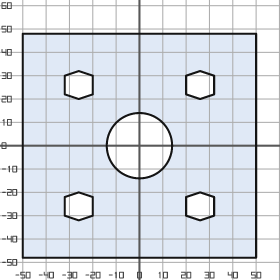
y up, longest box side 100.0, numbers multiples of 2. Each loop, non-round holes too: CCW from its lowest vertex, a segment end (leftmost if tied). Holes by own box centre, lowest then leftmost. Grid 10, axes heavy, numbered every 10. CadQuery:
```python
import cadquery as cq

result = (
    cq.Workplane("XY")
    .moveTo(-50.0, -48.0)
    .lineTo(50.0, -48.0)
    .lineTo(50.0, 48.0)
    .lineTo(-50.0, 48.0)
    .close()
    .moveTo(-26.0, -32.0)
    .lineTo(-20.0, -30.0)
    .lineTo(-20.0, -22.0)
    .lineTo(-26.0, -20.0)
    .lineTo(-32.0, -22.0)
    .lineTo(-32.0, -30.0)
    .close()
    .moveTo(26.0, -32.0)
    .lineTo(32.0, -30.0)
    .lineTo(32.0, -22.0)
    .lineTo(26.0, -20.0)
    .lineTo(20.0, -22.0)
    .lineTo(20.0, -30.0)
    .close()
    .moveTo(0.0, 0.0)
    .circle(14.0)
    .moveTo(-26.0, 20.0)
    .lineTo(-20.0, 22.0)
    .lineTo(-20.0, 30.0)
    .lineTo(-26.0, 32.0)
    .lineTo(-32.0, 30.0)
    .lineTo(-32.0, 22.0)
    .close()
    .moveTo(26.0, 20.0)
    .lineTo(32.0, 22.0)
    .lineTo(32.0, 30.0)
    .lineTo(26.0, 32.0)
    .lineTo(20.0, 30.0)
    .lineTo(20.0, 22.0)
    .close()
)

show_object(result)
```